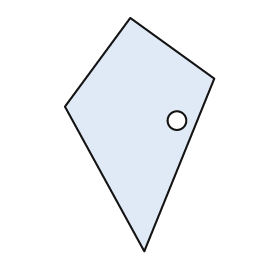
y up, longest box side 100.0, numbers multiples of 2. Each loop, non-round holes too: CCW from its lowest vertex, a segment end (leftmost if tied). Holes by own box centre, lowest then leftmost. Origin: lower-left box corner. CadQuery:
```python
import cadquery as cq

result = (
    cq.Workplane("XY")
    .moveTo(34.0, 0.0)
    .lineTo(64.0, 74.0)
    .lineTo(28.0, 100.0)
    .lineTo(0.0, 62.0)
    .close()
    .moveTo(48.0, 56.0)
    .circle(4.0)
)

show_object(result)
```